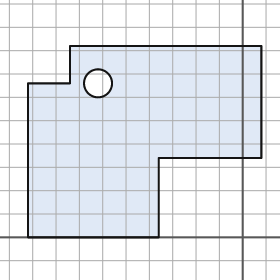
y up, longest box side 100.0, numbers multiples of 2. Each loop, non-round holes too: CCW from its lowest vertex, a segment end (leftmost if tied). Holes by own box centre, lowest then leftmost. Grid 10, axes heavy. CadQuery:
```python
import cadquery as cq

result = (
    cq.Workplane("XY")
    .moveTo(-92.0, 0.0)
    .lineTo(-36.0, 0.0)
    .lineTo(-36.0, 34.0)
    .lineTo(8.0, 34.0)
    .lineTo(8.0, 82.0)
    .lineTo(-74.0, 82.0)
    .lineTo(-74.0, 66.0)
    .lineTo(-92.0, 66.0)
    .close()
    .moveTo(-62.0, 66.0)
    .circle(6.0)
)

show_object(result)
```